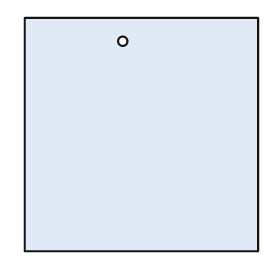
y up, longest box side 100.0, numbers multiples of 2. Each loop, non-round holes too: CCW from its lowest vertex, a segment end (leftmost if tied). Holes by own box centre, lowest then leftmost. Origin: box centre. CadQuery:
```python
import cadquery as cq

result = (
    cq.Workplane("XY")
    .moveTo(-50.0, -50.0)
    .lineTo(50.0, -50.0)
    .lineTo(50.0, 50.0)
    .lineTo(-50.0, 50.0)
    .close()
    .moveTo(-8.0, 40.0)
    .circle(2.0)
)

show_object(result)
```